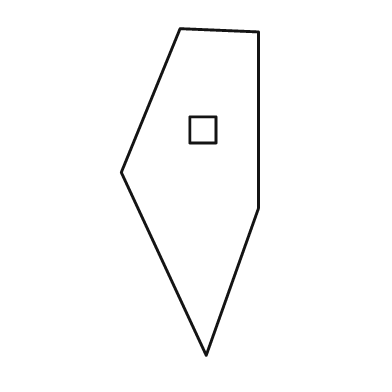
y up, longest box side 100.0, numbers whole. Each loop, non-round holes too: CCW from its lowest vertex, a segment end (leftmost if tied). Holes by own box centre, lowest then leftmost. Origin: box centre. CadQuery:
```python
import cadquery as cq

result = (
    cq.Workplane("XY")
    .moveTo(5.0, -50.0)
    .lineTo(21.0, -5.0)
    .lineTo(21.0, 49.0)
    .lineTo(-3.0, 50.0)
    .lineTo(-21.0, 6.0)
    .close()
    .moveTo(0.0, 15.0)
    .lineTo(8.0, 15.0)
    .lineTo(8.0, 23.0)
    .lineTo(0.0, 23.0)
    .close()
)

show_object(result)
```